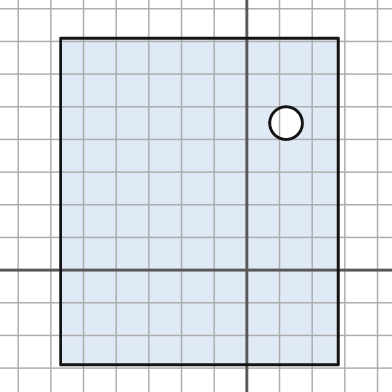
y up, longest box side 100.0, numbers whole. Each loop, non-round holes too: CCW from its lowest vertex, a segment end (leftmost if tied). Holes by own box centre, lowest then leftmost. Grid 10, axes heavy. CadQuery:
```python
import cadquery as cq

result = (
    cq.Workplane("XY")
    .moveTo(-57.0, -29.0)
    .lineTo(28.0, -29.0)
    .lineTo(28.0, 71.0)
    .lineTo(-57.0, 71.0)
    .close()
    .moveTo(12.0, 45.0)
    .circle(5.0)
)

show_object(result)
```